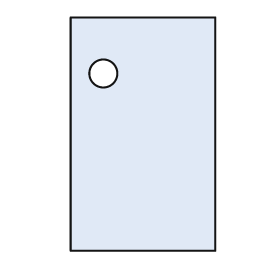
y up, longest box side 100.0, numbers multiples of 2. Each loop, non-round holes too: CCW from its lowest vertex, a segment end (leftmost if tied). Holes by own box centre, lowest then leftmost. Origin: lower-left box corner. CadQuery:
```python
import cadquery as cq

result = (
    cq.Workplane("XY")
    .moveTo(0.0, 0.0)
    .lineTo(62.0, 0.0)
    .lineTo(62.0, 100.0)
    .lineTo(0.0, 100.0)
    .close()
    .moveTo(14.0, 76.0)
    .circle(6.0)
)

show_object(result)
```